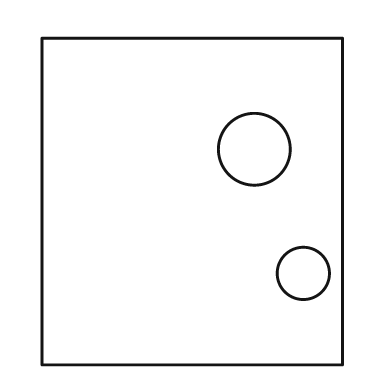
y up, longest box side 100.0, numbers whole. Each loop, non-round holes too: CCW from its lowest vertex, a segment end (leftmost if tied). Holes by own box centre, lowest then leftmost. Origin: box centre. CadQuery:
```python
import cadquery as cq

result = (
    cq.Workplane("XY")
    .moveTo(-46.0, -50.0)
    .lineTo(46.0, -50.0)
    .lineTo(46.0, 50.0)
    .lineTo(-46.0, 50.0)
    .close()
    .moveTo(34.0, -22.0)
    .circle(8.0)
    .moveTo(19.0, 16.0)
    .circle(11.0)
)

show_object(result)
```